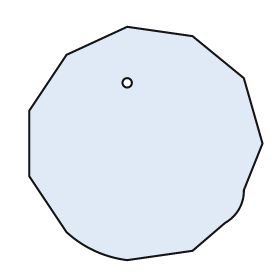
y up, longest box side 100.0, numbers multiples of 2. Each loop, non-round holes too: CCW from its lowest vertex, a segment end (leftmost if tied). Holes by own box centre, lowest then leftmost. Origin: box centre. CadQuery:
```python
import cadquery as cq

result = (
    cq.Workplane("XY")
    .moveTo(-8.0, -50.0)
    .lineTo(20.0, -46.0)
    .lineTo(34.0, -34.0)
    .threePointArc((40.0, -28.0), (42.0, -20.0))
    .lineTo(50.0, 0.0)
    .lineTo(42.0, 28.0)
    .lineTo(20.0, 46.0)
    .lineTo(-8.0, 50.0)
    .lineTo(-34.0, 38.0)
    .lineTo(-50.0, 14.0)
    .lineTo(-50.0, -14.0)
    .lineTo(-34.0, -38.0)
    .threePointArc((-22.0, -46.0), (-8.0, -50.0))
    .close()
    .moveTo(-8.0, 26.0)
    .circle(2.0)
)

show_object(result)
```